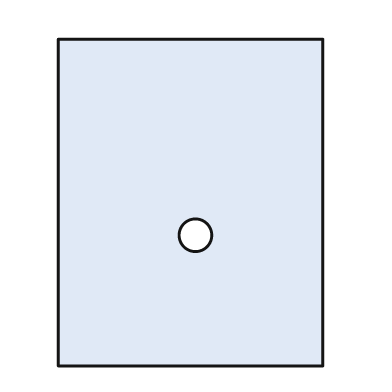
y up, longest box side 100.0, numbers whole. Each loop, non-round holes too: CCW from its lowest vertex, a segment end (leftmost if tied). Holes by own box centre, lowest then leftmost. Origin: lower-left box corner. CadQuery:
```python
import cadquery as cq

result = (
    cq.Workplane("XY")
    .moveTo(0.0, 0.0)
    .lineTo(81.0, 0.0)
    .lineTo(81.0, 100.0)
    .lineTo(0.0, 100.0)
    .close()
    .moveTo(42.0, 40.0)
    .circle(5.0)
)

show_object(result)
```